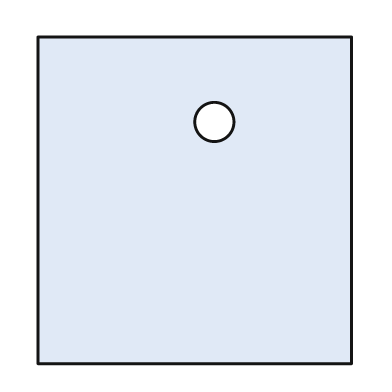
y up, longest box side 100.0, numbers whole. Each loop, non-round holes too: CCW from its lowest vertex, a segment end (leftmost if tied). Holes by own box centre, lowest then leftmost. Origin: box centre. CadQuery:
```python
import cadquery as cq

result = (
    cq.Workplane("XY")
    .moveTo(-48.0, -50.0)
    .lineTo(48.0, -50.0)
    .lineTo(48.0, 50.0)
    .lineTo(-48.0, 50.0)
    .close()
    .moveTo(6.0, 24.0)
    .circle(6.0)
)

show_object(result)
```